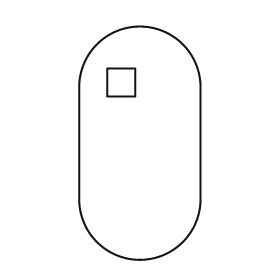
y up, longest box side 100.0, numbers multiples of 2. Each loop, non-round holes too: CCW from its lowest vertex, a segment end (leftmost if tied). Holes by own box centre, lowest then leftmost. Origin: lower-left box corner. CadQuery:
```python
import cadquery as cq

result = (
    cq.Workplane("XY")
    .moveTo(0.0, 26.0)
    .threePointArc((26.0, 0.0), (52.0, 26.0))
    .lineTo(52.0, 74.0)
    .threePointArc((26.0, 100.0), (0.0, 74.0))
    .close()
    .moveTo(12.0, 70.0)
    .lineTo(24.0, 70.0)
    .lineTo(24.0, 82.0)
    .lineTo(12.0, 82.0)
    .close()
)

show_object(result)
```